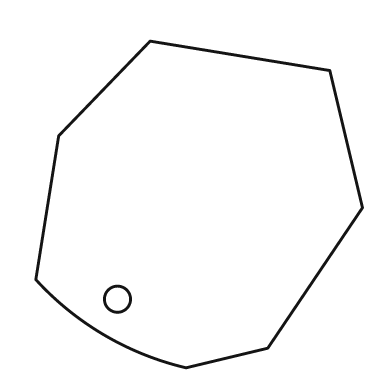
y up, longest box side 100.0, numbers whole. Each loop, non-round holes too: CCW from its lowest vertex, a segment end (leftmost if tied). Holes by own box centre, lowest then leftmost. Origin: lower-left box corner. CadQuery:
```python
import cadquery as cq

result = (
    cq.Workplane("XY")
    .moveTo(46.0, 0.0)
    .lineTo(71.0, 6.0)
    .lineTo(100.0, 49.0)
    .lineTo(90.0, 91.0)
    .lineTo(35.0, 100.0)
    .lineTo(7.0, 71.0)
    .lineTo(0.0, 27.0)
    .threePointArc((21.0, 10.0), (46.0, 0.0))
    .close()
    .moveTo(25.0, 21.0)
    .circle(4.0)
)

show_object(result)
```